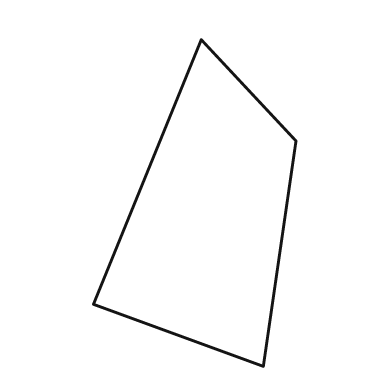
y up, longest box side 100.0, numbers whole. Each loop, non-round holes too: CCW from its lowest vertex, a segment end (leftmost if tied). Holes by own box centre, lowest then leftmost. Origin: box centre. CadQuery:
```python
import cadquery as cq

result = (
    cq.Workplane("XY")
    .moveTo(21.0, -50.0)
    .lineTo(31.0, 19.0)
    .lineTo(2.0, 50.0)
    .lineTo(-31.0, -31.0)
    .close()
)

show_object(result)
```